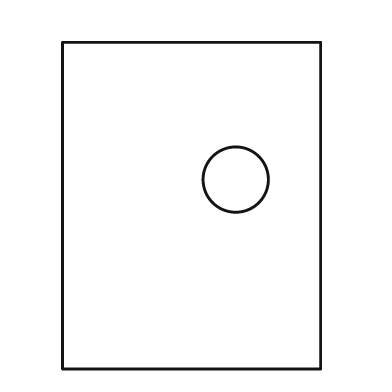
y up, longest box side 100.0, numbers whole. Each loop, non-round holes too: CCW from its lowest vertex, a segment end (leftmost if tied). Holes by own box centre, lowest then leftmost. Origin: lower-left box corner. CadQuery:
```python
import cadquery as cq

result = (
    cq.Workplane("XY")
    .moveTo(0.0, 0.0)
    .lineTo(79.0, 0.0)
    .lineTo(79.0, 100.0)
    .lineTo(0.0, 100.0)
    .close()
    .moveTo(53.0, 58.0)
    .circle(10.0)
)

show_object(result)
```